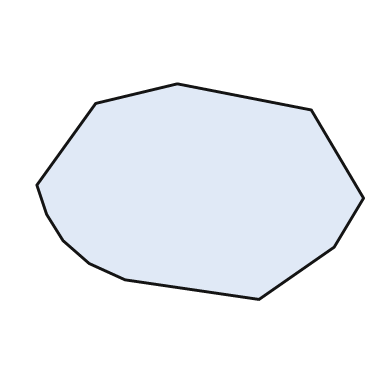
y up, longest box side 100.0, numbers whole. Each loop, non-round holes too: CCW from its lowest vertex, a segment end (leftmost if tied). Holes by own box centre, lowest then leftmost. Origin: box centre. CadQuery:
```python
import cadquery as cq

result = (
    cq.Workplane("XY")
    .moveTo(18.0, -33.0)
    .lineTo(41.0, -17.0)
    .lineTo(50.0, -2.0)
    .lineTo(34.0, 25.0)
    .lineTo(-7.0, 33.0)
    .lineTo(-32.0, 27.0)
    .lineTo(-50.0, 2.0)
    .lineTo(-47.0, -7.0)
    .lineTo(-42.0, -15.0)
    .lineTo(-34.0, -22.0)
    .lineTo(-23.0, -27.0)
    .close()
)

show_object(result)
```